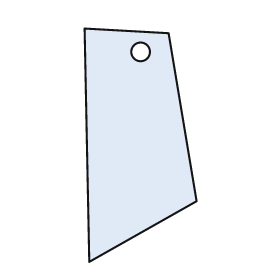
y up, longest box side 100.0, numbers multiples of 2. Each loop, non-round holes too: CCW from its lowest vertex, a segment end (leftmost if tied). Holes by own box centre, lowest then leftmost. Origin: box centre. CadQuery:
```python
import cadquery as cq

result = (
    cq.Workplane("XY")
    .moveTo(-22.0, -50.0)
    .lineTo(24.0, -24.0)
    .lineTo(12.0, 48.0)
    .lineTo(-24.0, 50.0)
    .close()
    .moveTo(0.0, 40.0)
    .circle(4.0)
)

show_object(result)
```